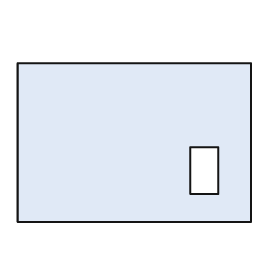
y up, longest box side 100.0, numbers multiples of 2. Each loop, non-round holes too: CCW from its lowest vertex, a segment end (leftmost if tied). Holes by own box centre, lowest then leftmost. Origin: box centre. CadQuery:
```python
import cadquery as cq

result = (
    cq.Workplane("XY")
    .moveTo(-50.0, -34.0)
    .lineTo(50.0, -34.0)
    .lineTo(50.0, 34.0)
    .lineTo(-50.0, 34.0)
    .close()
    .moveTo(24.0, -22.0)
    .lineTo(36.0, -22.0)
    .lineTo(36.0, -2.0)
    .lineTo(24.0, -2.0)
    .close()
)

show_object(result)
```